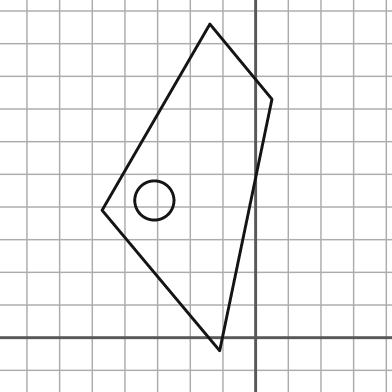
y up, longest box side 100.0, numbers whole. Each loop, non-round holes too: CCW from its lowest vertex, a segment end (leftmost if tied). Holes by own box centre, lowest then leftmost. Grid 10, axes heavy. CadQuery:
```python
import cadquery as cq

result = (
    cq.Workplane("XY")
    .moveTo(-11.0, -4.0)
    .lineTo(5.0, 73.0)
    .lineTo(-14.0, 96.0)
    .lineTo(-47.0, 39.0)
    .close()
    .moveTo(-31.0, 42.0)
    .circle(6.0)
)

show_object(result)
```